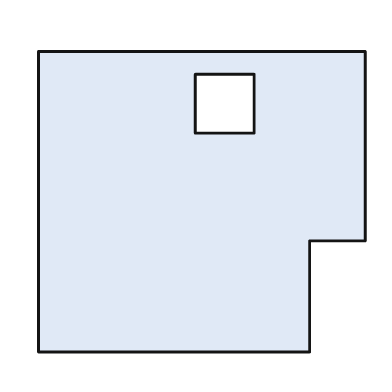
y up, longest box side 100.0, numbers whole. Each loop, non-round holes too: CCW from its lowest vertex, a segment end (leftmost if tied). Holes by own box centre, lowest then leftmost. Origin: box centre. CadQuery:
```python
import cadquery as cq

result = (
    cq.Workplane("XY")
    .moveTo(-50.0, -46.0)
    .lineTo(33.0, -46.0)
    .lineTo(33.0, -12.0)
    .lineTo(50.0, -12.0)
    .lineTo(50.0, 46.0)
    .lineTo(-50.0, 46.0)
    .close()
    .moveTo(-2.0, 21.0)
    .lineTo(16.0, 21.0)
    .lineTo(16.0, 39.0)
    .lineTo(-2.0, 39.0)
    .close()
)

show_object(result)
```